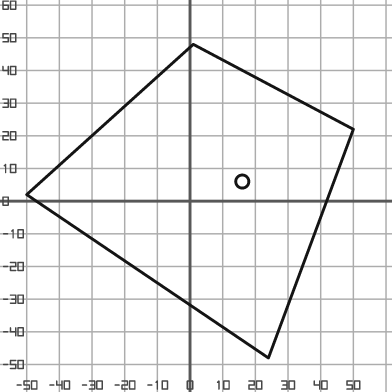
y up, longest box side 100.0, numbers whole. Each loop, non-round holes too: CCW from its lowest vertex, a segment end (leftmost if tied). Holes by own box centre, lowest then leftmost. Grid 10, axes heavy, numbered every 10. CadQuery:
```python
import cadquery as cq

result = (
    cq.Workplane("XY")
    .moveTo(24.0, -48.0)
    .lineTo(50.0, 22.0)
    .lineTo(1.0, 48.0)
    .lineTo(-50.0, 2.0)
    .close()
    .moveTo(16.0, 6.0)
    .circle(2.0)
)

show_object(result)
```